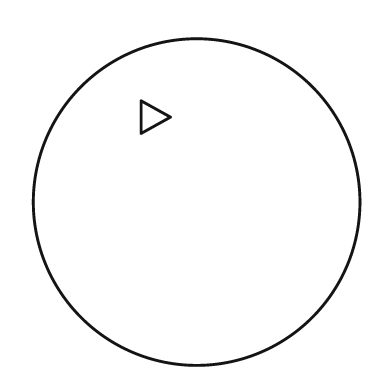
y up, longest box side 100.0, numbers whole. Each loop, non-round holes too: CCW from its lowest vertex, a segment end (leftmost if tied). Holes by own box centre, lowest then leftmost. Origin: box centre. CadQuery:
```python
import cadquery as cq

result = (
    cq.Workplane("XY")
    .moveTo(0.0, 0.0)
    .circle(50.0)
    .moveTo(-17.0, 21.0)
    .lineTo(-8.0, 26.0)
    .lineTo(-17.0, 31.0)
    .close()
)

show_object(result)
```